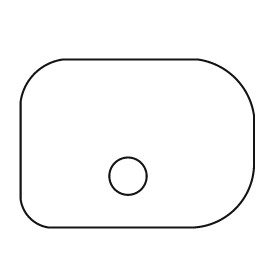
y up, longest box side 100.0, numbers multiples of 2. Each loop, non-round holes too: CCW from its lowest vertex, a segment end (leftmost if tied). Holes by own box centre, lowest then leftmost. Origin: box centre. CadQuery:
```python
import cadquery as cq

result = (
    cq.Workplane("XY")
    .moveTo(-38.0, -36.0)
    .lineTo(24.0, -36.0)
    .threePointArc((42.0, -28.0), (50.0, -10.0))
    .lineTo(50.0, 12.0)
    .threePointArc((42.0, 28.0), (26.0, 36.0))
    .lineTo(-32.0, 36.0)
    .threePointArc((-44.0, 30.0), (-50.0, 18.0))
    .lineTo(-50.0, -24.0)
    .threePointArc((-46.0, -32.0), (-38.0, -36.0))
    .close()
    .moveTo(-4.0, -14.0)
    .circle(8.0)
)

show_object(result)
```